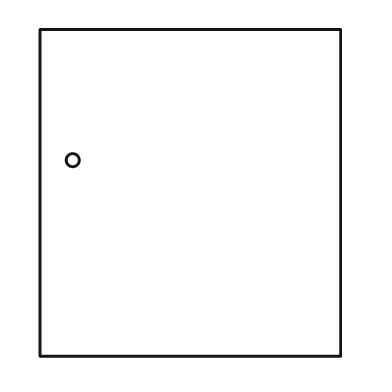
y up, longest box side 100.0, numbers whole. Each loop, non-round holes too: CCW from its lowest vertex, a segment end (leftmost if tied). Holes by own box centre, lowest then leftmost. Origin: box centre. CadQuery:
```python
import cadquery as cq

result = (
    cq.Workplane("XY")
    .moveTo(-46.0, -50.0)
    .lineTo(46.0, -50.0)
    .lineTo(46.0, 50.0)
    .lineTo(-46.0, 50.0)
    .close()
    .moveTo(-36.0, 10.0)
    .circle(2.0)
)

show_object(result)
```